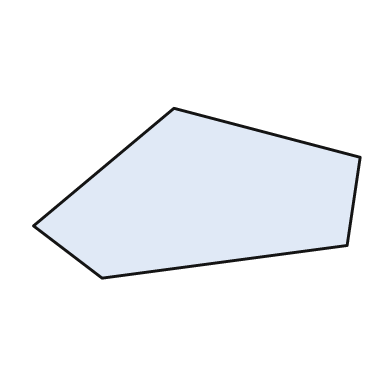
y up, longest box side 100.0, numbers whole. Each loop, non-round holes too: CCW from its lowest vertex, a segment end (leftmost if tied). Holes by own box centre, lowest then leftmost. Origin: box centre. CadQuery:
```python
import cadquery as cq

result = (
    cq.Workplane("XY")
    .moveTo(-29.0, -26.0)
    .lineTo(46.0, -16.0)
    .lineTo(50.0, 11.0)
    .lineTo(-7.0, 26.0)
    .lineTo(-50.0, -10.0)
    .close()
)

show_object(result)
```